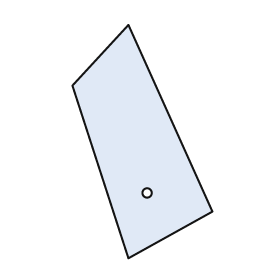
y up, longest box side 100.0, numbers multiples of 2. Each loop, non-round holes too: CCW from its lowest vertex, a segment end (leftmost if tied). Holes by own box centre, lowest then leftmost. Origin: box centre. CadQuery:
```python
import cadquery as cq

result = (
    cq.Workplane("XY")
    .moveTo(-6.0, -50.0)
    .lineTo(30.0, -30.0)
    .lineTo(-6.0, 50.0)
    .lineTo(-30.0, 24.0)
    .close()
    .moveTo(2.0, -22.0)
    .circle(2.0)
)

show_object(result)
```